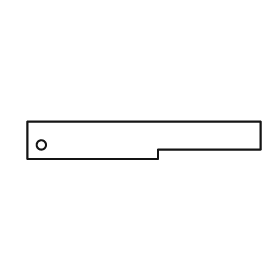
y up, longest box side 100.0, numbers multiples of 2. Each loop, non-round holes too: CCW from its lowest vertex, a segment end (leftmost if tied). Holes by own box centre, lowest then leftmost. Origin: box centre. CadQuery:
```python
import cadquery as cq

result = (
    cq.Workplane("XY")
    .moveTo(-50.0, -8.0)
    .lineTo(6.0, -8.0)
    .lineTo(6.0, -4.0)
    .lineTo(50.0, -4.0)
    .lineTo(50.0, 8.0)
    .lineTo(-50.0, 8.0)
    .close()
    .moveTo(-44.0, -2.0)
    .circle(2.0)
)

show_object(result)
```